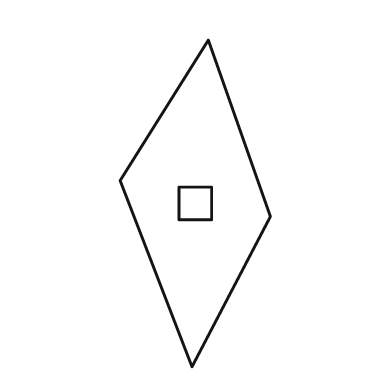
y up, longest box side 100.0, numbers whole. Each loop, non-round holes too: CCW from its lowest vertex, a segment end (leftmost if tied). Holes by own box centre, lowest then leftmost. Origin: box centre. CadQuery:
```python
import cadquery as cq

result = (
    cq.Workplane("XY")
    .moveTo(-1.0, -50.0)
    .lineTo(23.0, -4.0)
    .lineTo(4.0, 50.0)
    .lineTo(-23.0, 7.0)
    .close()
    .moveTo(-5.0, -5.0)
    .lineTo(5.0, -5.0)
    .lineTo(5.0, 5.0)
    .lineTo(-5.0, 5.0)
    .close()
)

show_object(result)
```